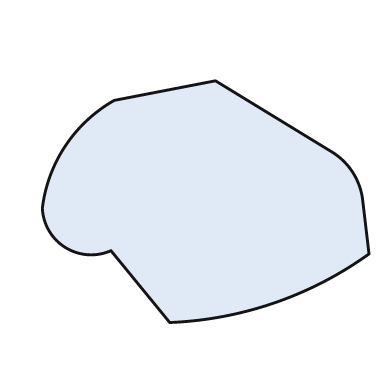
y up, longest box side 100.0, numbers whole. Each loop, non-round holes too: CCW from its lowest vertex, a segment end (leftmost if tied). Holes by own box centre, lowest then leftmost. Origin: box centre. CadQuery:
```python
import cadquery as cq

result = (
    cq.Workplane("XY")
    .moveTo(-11.0, -37.0)
    .threePointArc((21.0, -31.0), (50.0, -16.0))
    .lineTo(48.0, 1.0)
    .threePointArc((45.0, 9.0), (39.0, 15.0))
    .lineTo(3.0, 37.0)
    .lineTo(-28.0, 31.0)
    .threePointArc((-43.0, 17.0), (-50.0, -2.0))
    .threePointArc((-43.0, -14.0), (-29.0, -15.0))
    .close()
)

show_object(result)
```